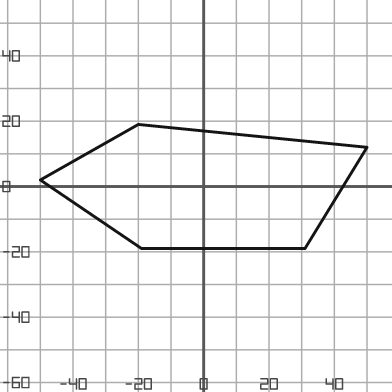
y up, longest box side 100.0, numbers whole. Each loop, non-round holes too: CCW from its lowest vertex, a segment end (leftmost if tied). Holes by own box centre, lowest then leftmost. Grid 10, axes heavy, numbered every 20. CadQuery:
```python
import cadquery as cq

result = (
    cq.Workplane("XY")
    .moveTo(-19.0, -19.0)
    .lineTo(31.0, -19.0)
    .lineTo(50.0, 12.0)
    .lineTo(-20.0, 19.0)
    .lineTo(-50.0, 2.0)
    .close()
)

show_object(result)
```